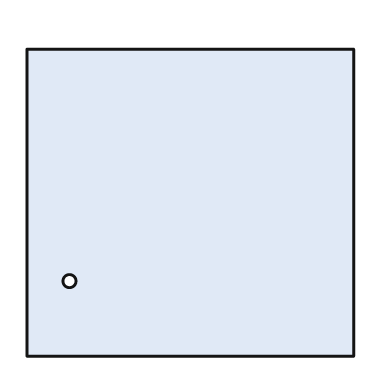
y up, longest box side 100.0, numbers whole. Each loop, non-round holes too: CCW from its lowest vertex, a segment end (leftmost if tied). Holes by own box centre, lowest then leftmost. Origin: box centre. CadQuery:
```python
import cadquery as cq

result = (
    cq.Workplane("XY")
    .moveTo(-50.0, -47.0)
    .lineTo(50.0, -47.0)
    .lineTo(50.0, 47.0)
    .lineTo(-50.0, 47.0)
    .close()
    .moveTo(-37.0, -24.0)
    .circle(2.0)
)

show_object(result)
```